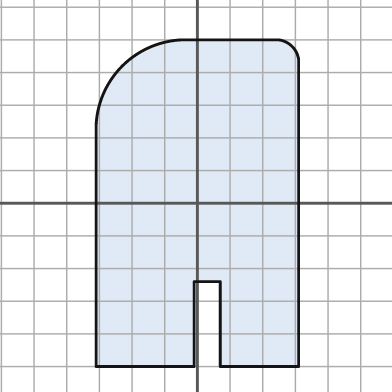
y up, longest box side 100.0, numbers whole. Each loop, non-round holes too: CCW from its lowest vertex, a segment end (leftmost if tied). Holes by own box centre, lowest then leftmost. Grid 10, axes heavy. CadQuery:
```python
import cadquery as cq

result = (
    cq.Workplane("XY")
    .moveTo(-31.0, -50.0)
    .lineTo(-1.0, -50.0)
    .lineTo(-1.0, -24.0)
    .lineTo(7.0, -24.0)
    .lineTo(7.0, -50.0)
    .lineTo(31.0, -50.0)
    .lineTo(31.0, 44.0)
    .threePointArc((29.0, 48.0), (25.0, 50.0))
    .lineTo(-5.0, 50.0)
    .threePointArc((-23.0, 42.0), (-31.0, 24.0))
    .close()
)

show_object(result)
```